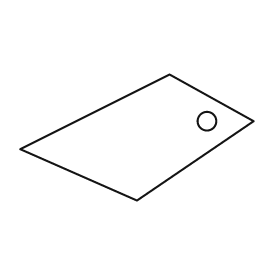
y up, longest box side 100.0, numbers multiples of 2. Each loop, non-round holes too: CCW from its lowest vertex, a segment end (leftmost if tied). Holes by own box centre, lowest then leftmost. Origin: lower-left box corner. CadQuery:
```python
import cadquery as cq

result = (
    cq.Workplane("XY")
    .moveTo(50.0, 0.0)
    .lineTo(100.0, 34.0)
    .lineTo(64.0, 54.0)
    .lineTo(0.0, 22.0)
    .close()
    .moveTo(80.0, 34.0)
    .circle(4.0)
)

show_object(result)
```